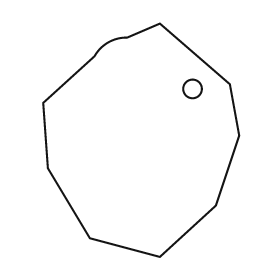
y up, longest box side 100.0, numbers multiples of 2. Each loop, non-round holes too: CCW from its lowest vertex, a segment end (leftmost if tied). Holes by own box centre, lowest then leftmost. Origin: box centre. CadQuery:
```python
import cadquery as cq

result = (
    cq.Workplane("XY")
    .moveTo(8.0, -50.0)
    .lineTo(32.0, -28.0)
    .lineTo(42.0, 2.0)
    .lineTo(38.0, 24.0)
    .lineTo(8.0, 50.0)
    .lineTo(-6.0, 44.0)
    .threePointArc((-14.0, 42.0), (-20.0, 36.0))
    .lineTo(-42.0, 16.0)
    .lineTo(-40.0, -12.0)
    .lineTo(-22.0, -42.0)
    .close()
    .moveTo(22.0, 22.0)
    .circle(4.0)
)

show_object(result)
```